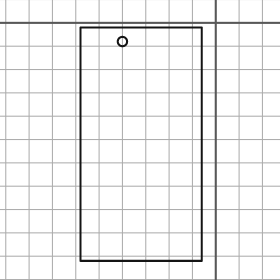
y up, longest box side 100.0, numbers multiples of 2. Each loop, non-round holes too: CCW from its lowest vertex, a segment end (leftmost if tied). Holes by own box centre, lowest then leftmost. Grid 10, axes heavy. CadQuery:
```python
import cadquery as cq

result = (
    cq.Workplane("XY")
    .moveTo(-58.0, -102.0)
    .lineTo(-6.0, -102.0)
    .lineTo(-6.0, -2.0)
    .lineTo(-58.0, -2.0)
    .close()
    .moveTo(-40.0, -8.0)
    .circle(2.0)
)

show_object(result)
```